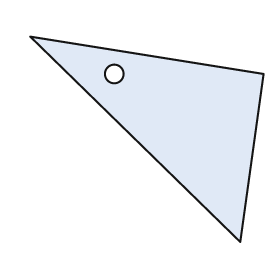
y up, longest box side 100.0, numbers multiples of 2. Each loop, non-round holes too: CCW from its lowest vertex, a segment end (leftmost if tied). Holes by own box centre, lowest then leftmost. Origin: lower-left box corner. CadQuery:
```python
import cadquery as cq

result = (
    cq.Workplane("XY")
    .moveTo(90.0, 0.0)
    .lineTo(100.0, 72.0)
    .lineTo(0.0, 88.0)
    .close()
    .moveTo(36.0, 72.0)
    .circle(4.0)
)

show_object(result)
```